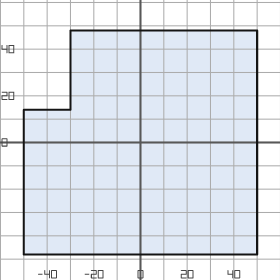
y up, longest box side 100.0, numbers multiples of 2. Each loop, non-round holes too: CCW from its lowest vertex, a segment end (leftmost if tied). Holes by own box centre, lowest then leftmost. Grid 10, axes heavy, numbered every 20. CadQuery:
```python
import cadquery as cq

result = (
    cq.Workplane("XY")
    .moveTo(-50.0, -48.0)
    .lineTo(50.0, -48.0)
    .lineTo(50.0, 48.0)
    .lineTo(-30.0, 48.0)
    .lineTo(-30.0, 14.0)
    .lineTo(-50.0, 14.0)
    .close()
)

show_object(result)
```